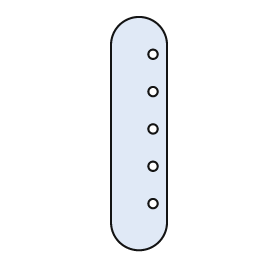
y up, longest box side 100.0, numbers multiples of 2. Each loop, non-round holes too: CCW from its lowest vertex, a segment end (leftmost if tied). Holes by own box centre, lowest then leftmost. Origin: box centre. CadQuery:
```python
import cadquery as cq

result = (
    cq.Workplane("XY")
    .moveTo(-12.0, -38.0)
    .threePointArc((0.0, -50.0), (12.0, -38.0))
    .lineTo(12.0, 38.0)
    .threePointArc((0.0, 50.0), (-12.0, 38.0))
    .close()
    .moveTo(6.0, -30.0)
    .circle(2.0)
    .moveTo(6.0, -14.0)
    .circle(2.0)
    .moveTo(6.0, 2.0)
    .circle(2.0)
    .moveTo(6.0, 18.0)
    .circle(2.0)
    .moveTo(6.0, 34.0)
    .circle(2.0)
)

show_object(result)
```